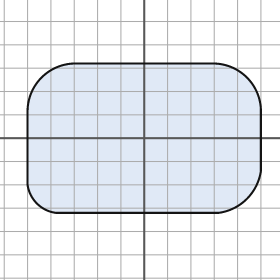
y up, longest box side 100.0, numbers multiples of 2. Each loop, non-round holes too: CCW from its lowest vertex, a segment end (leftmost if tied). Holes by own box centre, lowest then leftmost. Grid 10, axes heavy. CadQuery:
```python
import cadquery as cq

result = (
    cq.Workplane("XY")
    .moveTo(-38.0, -32.0)
    .lineTo(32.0, -32.0)
    .threePointArc((44.0, -26.0), (50.0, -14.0))
    .lineTo(50.0, 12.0)
    .threePointArc((44.0, 26.0), (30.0, 32.0))
    .lineTo(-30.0, 32.0)
    .threePointArc((-44.0, 26.0), (-50.0, 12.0))
    .lineTo(-50.0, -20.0)
    .threePointArc((-46.0, -28.0), (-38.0, -32.0))
    .close()
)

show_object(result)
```